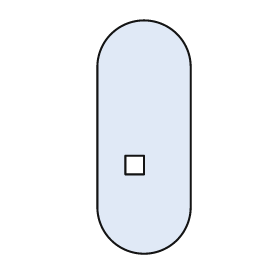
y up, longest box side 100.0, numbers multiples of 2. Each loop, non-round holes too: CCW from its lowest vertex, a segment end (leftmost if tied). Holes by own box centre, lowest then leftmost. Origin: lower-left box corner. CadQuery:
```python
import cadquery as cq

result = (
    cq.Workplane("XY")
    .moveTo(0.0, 20.0)
    .threePointArc((20.0, 0.0), (40.0, 20.0))
    .lineTo(40.0, 80.0)
    .threePointArc((20.0, 100.0), (0.0, 80.0))
    .close()
    .moveTo(12.0, 34.0)
    .lineTo(20.0, 34.0)
    .lineTo(20.0, 42.0)
    .lineTo(12.0, 42.0)
    .close()
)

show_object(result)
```